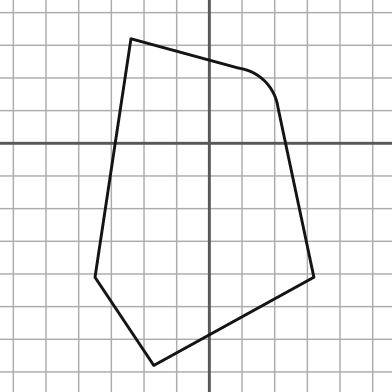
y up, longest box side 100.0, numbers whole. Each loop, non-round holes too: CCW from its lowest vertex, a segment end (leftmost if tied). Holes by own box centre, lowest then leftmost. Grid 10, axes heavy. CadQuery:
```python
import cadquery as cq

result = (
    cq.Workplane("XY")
    .moveTo(-17.0, -68.0)
    .lineTo(32.0, -41.0)
    .lineTo(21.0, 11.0)
    .threePointArc((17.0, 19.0), (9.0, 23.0))
    .lineTo(-24.0, 32.0)
    .lineTo(-35.0, -41.0)
    .close()
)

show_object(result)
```